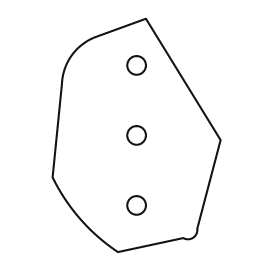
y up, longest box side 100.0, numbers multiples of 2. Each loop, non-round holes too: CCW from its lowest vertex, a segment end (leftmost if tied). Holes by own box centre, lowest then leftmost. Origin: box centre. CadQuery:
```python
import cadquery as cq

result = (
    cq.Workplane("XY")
    .moveTo(-8.0, -50.0)
    .lineTo(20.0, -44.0)
    .threePointArc((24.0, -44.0), (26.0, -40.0))
    .lineTo(36.0, -2.0)
    .lineTo(4.0, 50.0)
    .lineTo(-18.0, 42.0)
    .threePointArc((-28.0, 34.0), (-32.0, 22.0))
    .lineTo(-36.0, -18.0)
    .threePointArc((-24.0, -36.0), (-8.0, -50.0))
    .close()
    .moveTo(0.0, -30.0)
    .circle(4.0)
    .moveTo(0.0, 0.0)
    .circle(4.0)
    .moveTo(0.0, 30.0)
    .circle(4.0)
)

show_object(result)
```